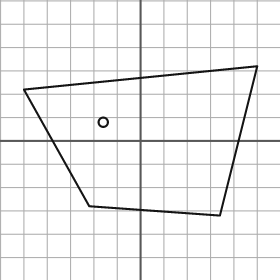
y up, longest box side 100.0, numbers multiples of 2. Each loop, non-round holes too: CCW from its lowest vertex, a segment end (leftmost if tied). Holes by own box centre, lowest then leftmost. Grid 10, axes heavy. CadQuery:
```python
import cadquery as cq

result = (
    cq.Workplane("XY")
    .moveTo(34.0, -32.0)
    .lineTo(50.0, 32.0)
    .lineTo(-50.0, 22.0)
    .lineTo(-22.0, -28.0)
    .close()
    .moveTo(-16.0, 8.0)
    .circle(2.0)
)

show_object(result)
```